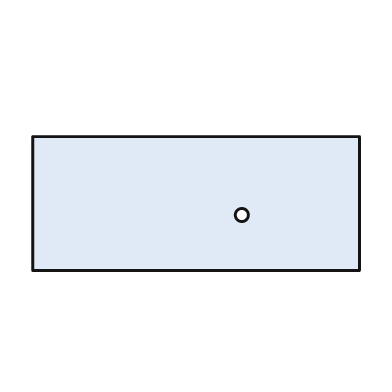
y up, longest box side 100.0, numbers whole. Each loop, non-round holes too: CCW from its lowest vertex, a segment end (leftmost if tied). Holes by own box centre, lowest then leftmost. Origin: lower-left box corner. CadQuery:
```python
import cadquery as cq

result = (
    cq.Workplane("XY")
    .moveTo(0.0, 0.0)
    .lineTo(100.0, 0.0)
    .lineTo(100.0, 41.0)
    .lineTo(0.0, 41.0)
    .close()
    .moveTo(64.0, 17.0)
    .circle(2.0)
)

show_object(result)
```